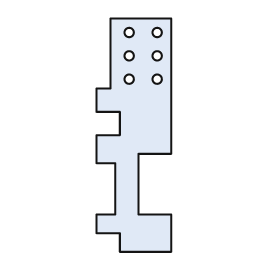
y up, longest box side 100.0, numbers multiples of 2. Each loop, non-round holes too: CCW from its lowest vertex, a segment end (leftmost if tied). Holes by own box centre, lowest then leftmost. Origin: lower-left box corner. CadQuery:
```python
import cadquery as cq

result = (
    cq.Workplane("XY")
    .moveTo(10.0, 0.0)
    .lineTo(32.0, 0.0)
    .lineTo(32.0, 16.0)
    .lineTo(18.0, 16.0)
    .lineTo(18.0, 42.0)
    .lineTo(32.0, 42.0)
    .lineTo(32.0, 100.0)
    .lineTo(6.0, 100.0)
    .lineTo(6.0, 70.0)
    .lineTo(0.0, 70.0)
    .lineTo(0.0, 60.0)
    .lineTo(10.0, 60.0)
    .lineTo(10.0, 50.0)
    .lineTo(0.0, 50.0)
    .lineTo(0.0, 38.0)
    .lineTo(8.0, 38.0)
    .lineTo(8.0, 16.0)
    .lineTo(0.0, 16.0)
    .lineTo(0.0, 8.0)
    .lineTo(10.0, 8.0)
    .close()
    .moveTo(14.0, 74.0)
    .circle(2.0)
    .moveTo(26.0, 74.0)
    .circle(2.0)
    .moveTo(14.0, 84.0)
    .circle(2.0)
    .moveTo(26.0, 84.0)
    .circle(2.0)
    .moveTo(14.0, 94.0)
    .circle(2.0)
    .moveTo(26.0, 94.0)
    .circle(2.0)
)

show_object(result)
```